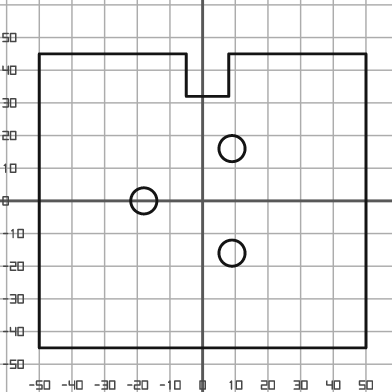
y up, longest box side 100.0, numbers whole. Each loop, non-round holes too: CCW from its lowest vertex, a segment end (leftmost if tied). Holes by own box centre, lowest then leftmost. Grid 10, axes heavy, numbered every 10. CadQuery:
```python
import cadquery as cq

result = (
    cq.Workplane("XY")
    .moveTo(-50.0, -45.0)
    .lineTo(50.0, -45.0)
    .lineTo(50.0, 45.0)
    .lineTo(8.0, 45.0)
    .lineTo(8.0, 32.0)
    .lineTo(-5.0, 32.0)
    .lineTo(-5.0, 45.0)
    .lineTo(-50.0, 45.0)
    .close()
    .moveTo(9.0, -16.0)
    .circle(4.0)
    .moveTo(-18.0, 0.0)
    .circle(4.0)
    .moveTo(9.0, 16.0)
    .circle(4.0)
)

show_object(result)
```